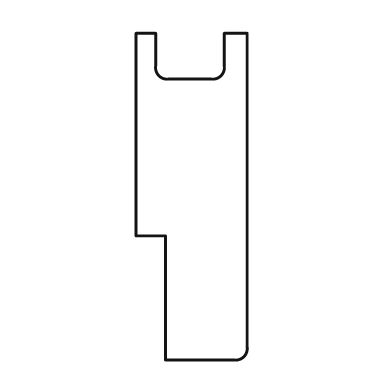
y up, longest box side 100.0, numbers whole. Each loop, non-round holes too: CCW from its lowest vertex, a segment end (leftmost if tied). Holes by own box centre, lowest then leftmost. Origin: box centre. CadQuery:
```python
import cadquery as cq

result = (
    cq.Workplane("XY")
    .moveTo(-8.0, -50.0)
    .lineTo(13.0, -50.0)
    .threePointArc((16.0, -49.0), (17.0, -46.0))
    .lineTo(17.0, 50.0)
    .lineTo(10.0, 50.0)
    .lineTo(10.0, 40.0)
    .threePointArc((9.0, 37.0), (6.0, 36.0))
    .lineTo(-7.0, 36.0)
    .threePointArc((-10.0, 37.0), (-11.0, 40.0))
    .lineTo(-11.0, 50.0)
    .lineTo(-17.0, 50.0)
    .lineTo(-17.0, -12.0)
    .lineTo(-8.0, -12.0)
    .close()
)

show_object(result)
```